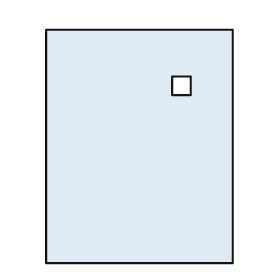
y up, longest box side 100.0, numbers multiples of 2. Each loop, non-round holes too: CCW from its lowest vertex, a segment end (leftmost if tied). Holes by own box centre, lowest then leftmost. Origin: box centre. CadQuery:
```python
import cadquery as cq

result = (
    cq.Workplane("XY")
    .moveTo(-40.0, -50.0)
    .lineTo(40.0, -50.0)
    .lineTo(40.0, 50.0)
    .lineTo(-40.0, 50.0)
    .close()
    .moveTo(14.0, 22.0)
    .lineTo(22.0, 22.0)
    .lineTo(22.0, 30.0)
    .lineTo(14.0, 30.0)
    .close()
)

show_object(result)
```